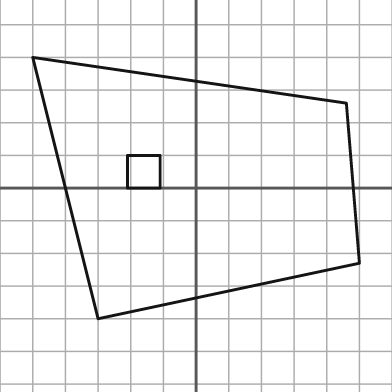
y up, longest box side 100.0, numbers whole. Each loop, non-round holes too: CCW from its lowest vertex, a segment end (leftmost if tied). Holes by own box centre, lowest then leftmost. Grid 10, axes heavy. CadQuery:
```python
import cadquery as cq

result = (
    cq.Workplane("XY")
    .moveTo(-30.0, -40.0)
    .lineTo(50.0, -23.0)
    .lineTo(46.0, 26.0)
    .lineTo(-50.0, 40.0)
    .close()
    .moveTo(-21.0, 0.0)
    .lineTo(-11.0, 0.0)
    .lineTo(-11.0, 10.0)
    .lineTo(-21.0, 10.0)
    .close()
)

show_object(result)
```